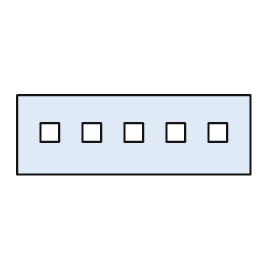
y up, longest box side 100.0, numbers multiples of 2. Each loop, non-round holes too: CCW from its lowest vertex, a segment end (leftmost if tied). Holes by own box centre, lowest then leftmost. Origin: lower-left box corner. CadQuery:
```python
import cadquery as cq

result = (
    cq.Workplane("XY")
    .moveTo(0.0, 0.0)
    .lineTo(100.0, 0.0)
    .lineTo(100.0, 34.0)
    .lineTo(0.0, 34.0)
    .close()
    .moveTo(10.0, 14.0)
    .lineTo(18.0, 14.0)
    .lineTo(18.0, 22.0)
    .lineTo(10.0, 22.0)
    .close()
    .moveTo(28.0, 14.0)
    .lineTo(36.0, 14.0)
    .lineTo(36.0, 22.0)
    .lineTo(28.0, 22.0)
    .close()
    .moveTo(46.0, 14.0)
    .lineTo(54.0, 14.0)
    .lineTo(54.0, 22.0)
    .lineTo(46.0, 22.0)
    .close()
    .moveTo(64.0, 14.0)
    .lineTo(72.0, 14.0)
    .lineTo(72.0, 22.0)
    .lineTo(64.0, 22.0)
    .close()
    .moveTo(82.0, 14.0)
    .lineTo(90.0, 14.0)
    .lineTo(90.0, 22.0)
    .lineTo(82.0, 22.0)
    .close()
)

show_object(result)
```